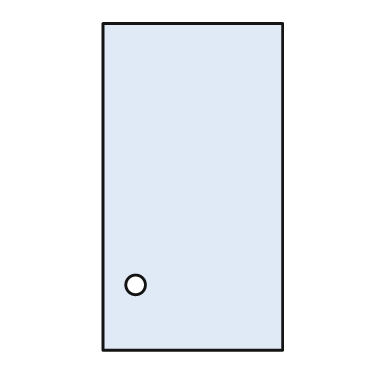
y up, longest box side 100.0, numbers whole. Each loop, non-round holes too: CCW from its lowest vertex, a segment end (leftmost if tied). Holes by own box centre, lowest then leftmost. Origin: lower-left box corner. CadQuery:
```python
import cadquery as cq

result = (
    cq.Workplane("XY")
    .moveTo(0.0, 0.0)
    .lineTo(55.0, 0.0)
    .lineTo(55.0, 100.0)
    .lineTo(0.0, 100.0)
    .close()
    .moveTo(10.0, 20.0)
    .circle(3.0)
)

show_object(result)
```